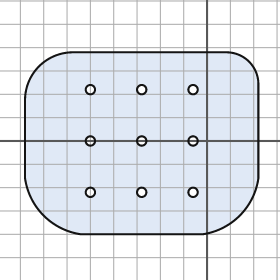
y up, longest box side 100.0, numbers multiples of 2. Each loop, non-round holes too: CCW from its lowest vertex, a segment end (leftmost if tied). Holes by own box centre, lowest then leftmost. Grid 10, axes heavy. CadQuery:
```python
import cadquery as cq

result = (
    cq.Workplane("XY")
    .moveTo(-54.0, -40.0)
    .lineTo(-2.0, -40.0)
    .threePointArc((14.0, -32.0), (22.0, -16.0))
    .lineTo(22.0, 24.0)
    .threePointArc((18.0, 34.0), (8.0, 38.0))
    .lineTo(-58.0, 38.0)
    .threePointArc((-72.0, 32.0), (-78.0, 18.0))
    .lineTo(-78.0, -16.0)
    .threePointArc((-70.0, -32.0), (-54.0, -40.0))
    .close()
    .moveTo(-50.0, -22.0)
    .circle(2.0)
    .moveTo(-28.0, -22.0)
    .circle(2.0)
    .moveTo(-6.0, -22.0)
    .circle(2.0)
    .moveTo(-50.0, 0.0)
    .circle(2.0)
    .moveTo(-28.0, 0.0)
    .circle(2.0)
    .moveTo(-6.0, 0.0)
    .circle(2.0)
    .moveTo(-50.0, 22.0)
    .circle(2.0)
    .moveTo(-28.0, 22.0)
    .circle(2.0)
    .moveTo(-6.0, 22.0)
    .circle(2.0)
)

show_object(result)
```